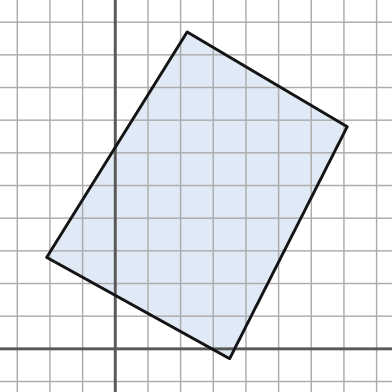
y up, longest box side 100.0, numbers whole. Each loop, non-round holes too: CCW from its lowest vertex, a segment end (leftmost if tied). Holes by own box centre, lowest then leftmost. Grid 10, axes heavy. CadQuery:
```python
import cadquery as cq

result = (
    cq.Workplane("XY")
    .moveTo(35.0, -3.0)
    .lineTo(71.0, 68.0)
    .lineTo(22.0, 97.0)
    .lineTo(-21.0, 28.0)
    .close()
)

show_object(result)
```